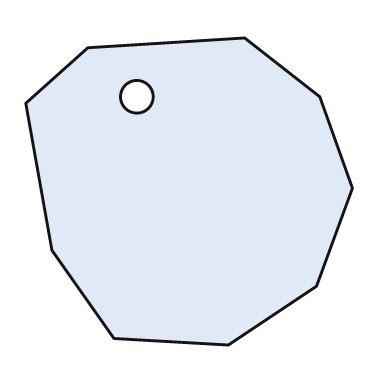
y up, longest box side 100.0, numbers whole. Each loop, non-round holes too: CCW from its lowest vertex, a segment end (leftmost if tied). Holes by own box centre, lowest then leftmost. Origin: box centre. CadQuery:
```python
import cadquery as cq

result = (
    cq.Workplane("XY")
    .moveTo(12.0, -47.0)
    .lineTo(39.0, -29.0)
    .lineTo(50.0, 1.0)
    .lineTo(40.0, 29.0)
    .lineTo(17.0, 47.0)
    .lineTo(-31.0, 44.0)
    .lineTo(-50.0, 27.0)
    .lineTo(-42.0, -18.0)
    .lineTo(-23.0, -45.0)
    .close()
    .moveTo(-16.0, 29.0)
    .circle(5.0)
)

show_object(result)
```